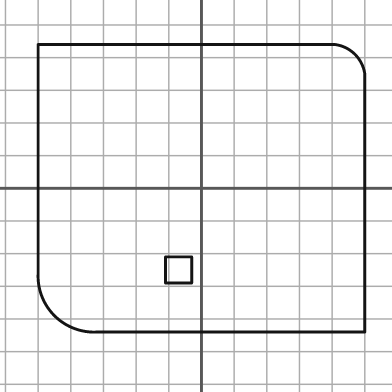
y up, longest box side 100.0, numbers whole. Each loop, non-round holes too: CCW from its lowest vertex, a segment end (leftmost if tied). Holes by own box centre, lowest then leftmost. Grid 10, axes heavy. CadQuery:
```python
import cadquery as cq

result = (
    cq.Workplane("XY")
    .moveTo(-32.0, -44.0)
    .lineTo(50.0, -44.0)
    .lineTo(50.0, 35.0)
    .threePointArc((47.0, 41.0), (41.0, 44.0))
    .lineTo(-50.0, 44.0)
    .lineTo(-50.0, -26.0)
    .threePointArc((-45.0, -39.0), (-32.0, -44.0))
    .close()
    .moveTo(-11.0, -29.0)
    .lineTo(-3.0, -29.0)
    .lineTo(-3.0, -21.0)
    .lineTo(-11.0, -21.0)
    .close()
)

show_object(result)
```